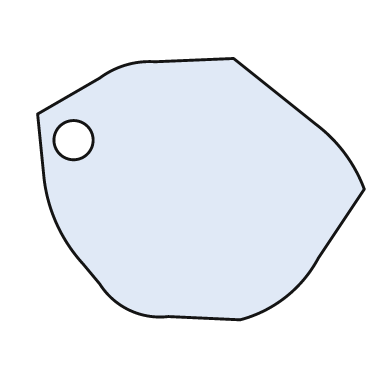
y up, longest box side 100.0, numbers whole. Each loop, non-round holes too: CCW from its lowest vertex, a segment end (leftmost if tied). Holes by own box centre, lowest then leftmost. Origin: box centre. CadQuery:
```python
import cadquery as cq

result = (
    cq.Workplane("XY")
    .moveTo(12.0, -40.0)
    .threePointArc((26.0, -33.0), (36.0, -21.0))
    .lineTo(50.0, 0.0)
    .threePointArc((44.0, 11.0), (35.0, 20.0))
    .lineTo(10.0, 40.0)
    .lineTo(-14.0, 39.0)
    .threePointArc((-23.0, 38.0), (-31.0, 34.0))
    .lineTo(-50.0, 23.0)
    .lineTo(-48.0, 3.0)
    .threePointArc((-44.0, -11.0), (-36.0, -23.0))
    .lineTo(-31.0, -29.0)
    .threePointArc((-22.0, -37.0), (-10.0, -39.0))
    .close()
    .moveTo(-39.0, 15.0)
    .circle(6.0)
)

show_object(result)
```